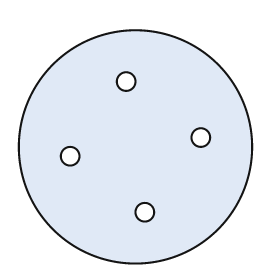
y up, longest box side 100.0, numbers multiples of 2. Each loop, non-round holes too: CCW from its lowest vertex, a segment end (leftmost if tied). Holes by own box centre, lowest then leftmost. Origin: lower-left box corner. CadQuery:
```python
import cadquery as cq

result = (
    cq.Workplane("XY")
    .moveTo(50.0, 50.0)
    .circle(50.0)
    .moveTo(54.0, 22.0)
    .circle(4.0)
    .moveTo(22.0, 46.0)
    .circle(4.0)
    .moveTo(78.0, 54.0)
    .circle(4.0)
    .moveTo(46.0, 78.0)
    .circle(4.0)
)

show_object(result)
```